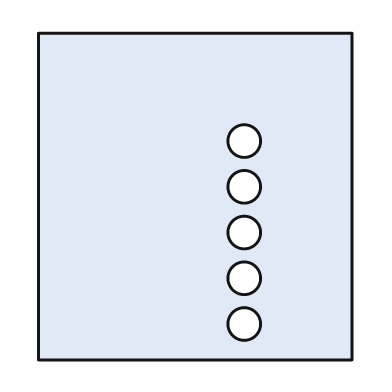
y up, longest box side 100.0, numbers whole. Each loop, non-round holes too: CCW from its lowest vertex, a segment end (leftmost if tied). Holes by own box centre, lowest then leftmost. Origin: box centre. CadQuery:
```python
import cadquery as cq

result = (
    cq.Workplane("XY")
    .moveTo(-48.0, -50.0)
    .lineTo(48.0, -50.0)
    .lineTo(48.0, 50.0)
    .lineTo(-48.0, 50.0)
    .close()
    .moveTo(15.0, -39.0)
    .circle(5.0)
    .moveTo(15.0, -25.0)
    .circle(5.0)
    .moveTo(15.0, -11.0)
    .circle(5.0)
    .moveTo(15.0, 3.0)
    .circle(5.0)
    .moveTo(15.0, 17.0)
    .circle(5.0)
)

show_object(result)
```